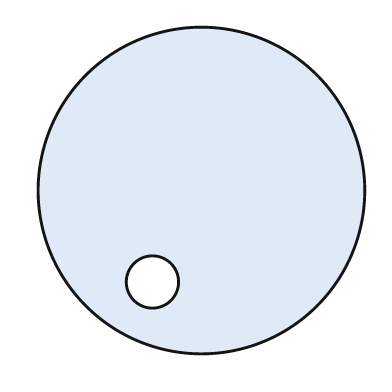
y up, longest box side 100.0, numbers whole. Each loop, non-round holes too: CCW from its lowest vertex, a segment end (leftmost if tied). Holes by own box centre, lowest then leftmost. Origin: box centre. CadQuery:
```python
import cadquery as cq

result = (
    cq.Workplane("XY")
    .moveTo(0.0, 0.0)
    .circle(50.0)
    .moveTo(-15.0, -28.0)
    .circle(8.0)
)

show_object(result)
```